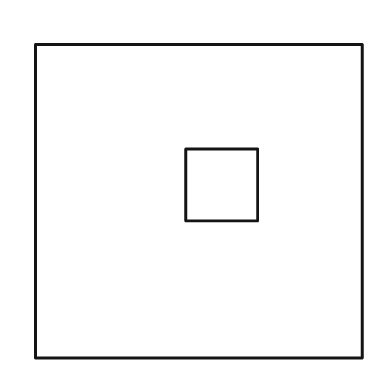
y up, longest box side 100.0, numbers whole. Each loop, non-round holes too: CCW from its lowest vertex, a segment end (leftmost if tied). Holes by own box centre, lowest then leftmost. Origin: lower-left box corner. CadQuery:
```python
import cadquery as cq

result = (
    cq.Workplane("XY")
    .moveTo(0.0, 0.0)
    .lineTo(100.0, 0.0)
    .lineTo(100.0, 96.0)
    .lineTo(0.0, 96.0)
    .close()
    .moveTo(46.0, 42.0)
    .lineTo(68.0, 42.0)
    .lineTo(68.0, 64.0)
    .lineTo(46.0, 64.0)
    .close()
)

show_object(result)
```